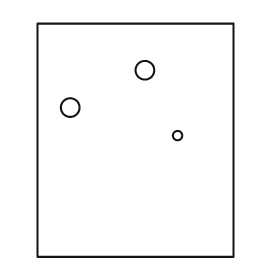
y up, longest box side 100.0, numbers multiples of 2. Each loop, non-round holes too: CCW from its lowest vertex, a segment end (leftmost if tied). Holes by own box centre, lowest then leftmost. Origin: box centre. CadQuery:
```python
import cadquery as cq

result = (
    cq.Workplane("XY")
    .moveTo(-42.0, -50.0)
    .lineTo(42.0, -50.0)
    .lineTo(42.0, 50.0)
    .lineTo(-42.0, 50.0)
    .close()
    .moveTo(18.0, 2.0)
    .circle(2.0)
    .moveTo(-28.0, 14.0)
    .circle(4.0)
    .moveTo(4.0, 30.0)
    .circle(4.0)
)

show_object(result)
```